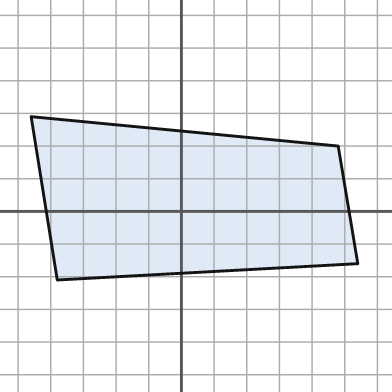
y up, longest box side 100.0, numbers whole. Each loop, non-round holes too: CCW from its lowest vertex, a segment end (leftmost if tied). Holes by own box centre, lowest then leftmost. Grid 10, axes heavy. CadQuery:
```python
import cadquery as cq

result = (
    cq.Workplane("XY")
    .moveTo(-38.0, -21.0)
    .lineTo(54.0, -16.0)
    .lineTo(48.0, 20.0)
    .lineTo(-46.0, 29.0)
    .close()
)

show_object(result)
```